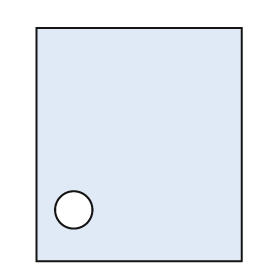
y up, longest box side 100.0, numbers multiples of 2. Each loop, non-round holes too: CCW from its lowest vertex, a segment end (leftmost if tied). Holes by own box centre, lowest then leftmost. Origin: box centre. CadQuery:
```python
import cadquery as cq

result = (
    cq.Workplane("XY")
    .moveTo(-44.0, -50.0)
    .lineTo(44.0, -50.0)
    .lineTo(44.0, 50.0)
    .lineTo(-44.0, 50.0)
    .close()
    .moveTo(-28.0, -28.0)
    .circle(8.0)
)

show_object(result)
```